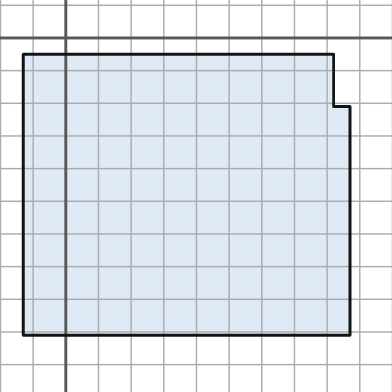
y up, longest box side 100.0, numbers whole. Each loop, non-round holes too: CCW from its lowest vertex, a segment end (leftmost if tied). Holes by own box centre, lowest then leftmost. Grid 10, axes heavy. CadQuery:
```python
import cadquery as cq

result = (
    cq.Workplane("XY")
    .moveTo(-13.0, -91.0)
    .lineTo(87.0, -91.0)
    .lineTo(87.0, -21.0)
    .lineTo(82.0, -21.0)
    .lineTo(82.0, -5.0)
    .lineTo(-13.0, -5.0)
    .close()
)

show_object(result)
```